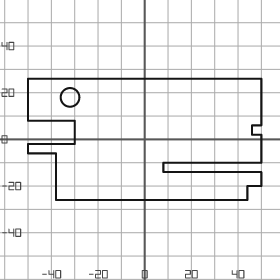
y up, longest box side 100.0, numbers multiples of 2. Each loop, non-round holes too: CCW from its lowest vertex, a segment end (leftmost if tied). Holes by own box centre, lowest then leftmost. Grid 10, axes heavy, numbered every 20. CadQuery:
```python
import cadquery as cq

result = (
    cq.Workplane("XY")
    .moveTo(-38.0, -26.0)
    .lineTo(44.0, -26.0)
    .lineTo(44.0, -20.0)
    .lineTo(50.0, -20.0)
    .lineTo(50.0, -14.0)
    .lineTo(8.0, -14.0)
    .lineTo(8.0, -10.0)
    .lineTo(50.0, -10.0)
    .lineTo(50.0, 2.0)
    .lineTo(46.0, 2.0)
    .lineTo(46.0, 6.0)
    .lineTo(50.0, 6.0)
    .lineTo(50.0, 26.0)
    .lineTo(-50.0, 26.0)
    .lineTo(-50.0, 8.0)
    .lineTo(-30.0, 8.0)
    .lineTo(-30.0, -2.0)
    .lineTo(-50.0, -2.0)
    .lineTo(-50.0, -6.0)
    .lineTo(-38.0, -6.0)
    .close()
    .moveTo(-32.0, 18.0)
    .circle(4.0)
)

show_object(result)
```